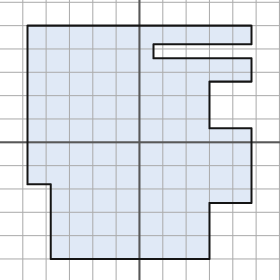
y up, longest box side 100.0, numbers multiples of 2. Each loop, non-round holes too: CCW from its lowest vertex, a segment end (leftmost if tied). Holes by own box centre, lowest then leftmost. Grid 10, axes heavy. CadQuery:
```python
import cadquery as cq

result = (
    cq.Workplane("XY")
    .moveTo(-38.0, -50.0)
    .lineTo(30.0, -50.0)
    .lineTo(30.0, -26.0)
    .lineTo(48.0, -26.0)
    .lineTo(48.0, 6.0)
    .lineTo(30.0, 6.0)
    .lineTo(30.0, 26.0)
    .lineTo(48.0, 26.0)
    .lineTo(48.0, 36.0)
    .lineTo(6.0, 36.0)
    .lineTo(6.0, 42.0)
    .lineTo(48.0, 42.0)
    .lineTo(48.0, 50.0)
    .lineTo(-48.0, 50.0)
    .lineTo(-48.0, -18.0)
    .lineTo(-38.0, -18.0)
    .close()
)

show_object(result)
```